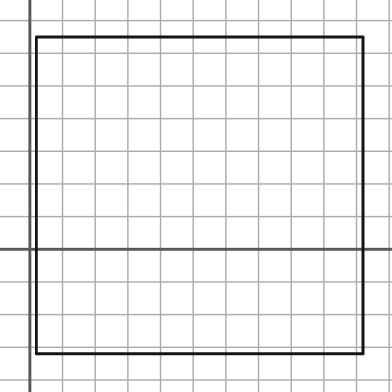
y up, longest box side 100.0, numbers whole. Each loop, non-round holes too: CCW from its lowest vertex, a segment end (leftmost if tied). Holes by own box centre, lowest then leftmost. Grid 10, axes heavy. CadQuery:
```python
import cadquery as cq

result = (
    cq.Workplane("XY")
    .moveTo(2.0, -32.0)
    .lineTo(102.0, -32.0)
    .lineTo(102.0, 65.0)
    .lineTo(2.0, 65.0)
    .close()
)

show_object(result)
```